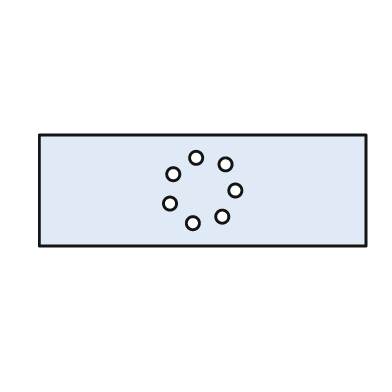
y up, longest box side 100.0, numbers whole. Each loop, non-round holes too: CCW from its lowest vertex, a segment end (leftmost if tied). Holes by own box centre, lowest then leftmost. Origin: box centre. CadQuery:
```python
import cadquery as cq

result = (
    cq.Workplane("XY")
    .moveTo(-50.0, -17.0)
    .lineTo(50.0, -17.0)
    .lineTo(50.0, 17.0)
    .lineTo(-50.0, 17.0)
    .close()
    .moveTo(-3.0, -10.0)
    .circle(2.0)
    .moveTo(6.0, -8.0)
    .circle(2.0)
    .moveTo(-10.0, -4.0)
    .circle(2.0)
    .moveTo(10.0, 0.0)
    .circle(2.0)
    .moveTo(-9.0, 5.0)
    .circle(2.0)
    .moveTo(7.0, 8.0)
    .circle(2.0)
    .moveTo(-2.0, 10.0)
    .circle(2.0)
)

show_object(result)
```